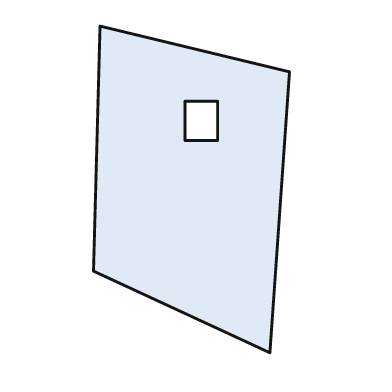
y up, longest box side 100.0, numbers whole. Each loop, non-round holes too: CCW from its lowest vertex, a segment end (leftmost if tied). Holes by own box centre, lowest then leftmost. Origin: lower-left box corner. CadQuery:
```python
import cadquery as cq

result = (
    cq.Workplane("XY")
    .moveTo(54.0, 0.0)
    .lineTo(60.0, 86.0)
    .lineTo(2.0, 100.0)
    .lineTo(0.0, 25.0)
    .close()
    .moveTo(28.0, 65.0)
    .lineTo(38.0, 65.0)
    .lineTo(38.0, 77.0)
    .lineTo(28.0, 77.0)
    .close()
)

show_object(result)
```